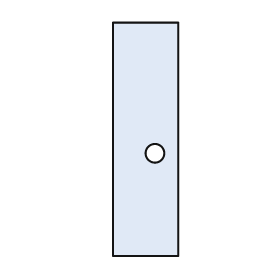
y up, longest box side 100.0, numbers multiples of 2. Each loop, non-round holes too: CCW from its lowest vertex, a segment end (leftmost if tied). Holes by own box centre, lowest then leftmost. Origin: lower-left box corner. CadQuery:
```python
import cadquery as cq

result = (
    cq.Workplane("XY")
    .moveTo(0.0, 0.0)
    .lineTo(28.0, 0.0)
    .lineTo(28.0, 100.0)
    .lineTo(0.0, 100.0)
    .close()
    .moveTo(18.0, 44.0)
    .circle(4.0)
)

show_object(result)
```